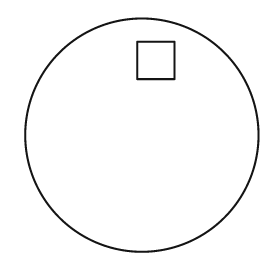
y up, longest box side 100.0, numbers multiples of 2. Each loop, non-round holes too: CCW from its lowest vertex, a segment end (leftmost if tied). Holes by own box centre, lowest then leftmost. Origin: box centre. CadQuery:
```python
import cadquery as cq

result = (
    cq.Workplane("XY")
    .moveTo(0.0, 0.0)
    .circle(50.0)
    .moveTo(-2.0, 24.0)
    .lineTo(14.0, 24.0)
    .lineTo(14.0, 40.0)
    .lineTo(-2.0, 40.0)
    .close()
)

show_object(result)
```